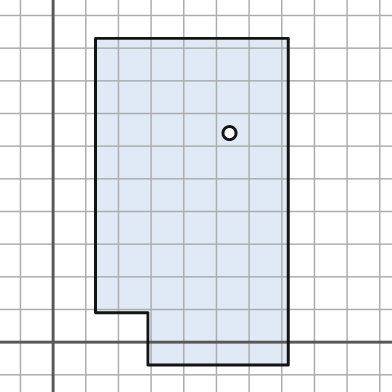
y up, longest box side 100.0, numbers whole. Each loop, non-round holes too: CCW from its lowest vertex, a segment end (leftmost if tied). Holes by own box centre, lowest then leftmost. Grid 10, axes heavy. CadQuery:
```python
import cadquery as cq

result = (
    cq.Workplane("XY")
    .moveTo(29.0, -7.0)
    .lineTo(72.0, -7.0)
    .lineTo(72.0, 93.0)
    .lineTo(13.0, 93.0)
    .lineTo(13.0, 9.0)
    .lineTo(29.0, 9.0)
    .close()
    .moveTo(54.0, 64.0)
    .circle(2.0)
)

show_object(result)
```